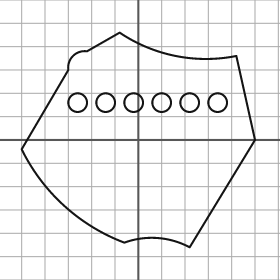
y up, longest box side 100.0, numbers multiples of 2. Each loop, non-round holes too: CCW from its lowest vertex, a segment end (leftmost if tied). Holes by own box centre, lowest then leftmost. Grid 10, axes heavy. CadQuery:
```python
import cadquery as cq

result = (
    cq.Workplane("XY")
    .moveTo(22.0, -46.0)
    .lineTo(50.0, 0.0)
    .lineTo(42.0, 36.0)
    .threePointArc((16.0, 36.0), (-8.0, 46.0))
    .lineTo(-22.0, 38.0)
    .threePointArc((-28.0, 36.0), (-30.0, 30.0))
    .lineTo(-50.0, -4.0)
    .threePointArc((-32.0, -28.0), (-6.0, -44.0))
    .threePointArc((8.0, -42.0), (22.0, -46.0))
    .close()
    .moveTo(-26.0, 16.0)
    .circle(4.0)
    .moveTo(-14.0, 16.0)
    .circle(4.0)
    .moveTo(-2.0, 16.0)
    .circle(4.0)
    .moveTo(10.0, 16.0)
    .circle(4.0)
    .moveTo(22.0, 16.0)
    .circle(4.0)
    .moveTo(34.0, 16.0)
    .circle(4.0)
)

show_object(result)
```